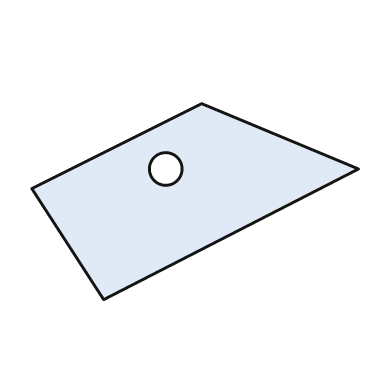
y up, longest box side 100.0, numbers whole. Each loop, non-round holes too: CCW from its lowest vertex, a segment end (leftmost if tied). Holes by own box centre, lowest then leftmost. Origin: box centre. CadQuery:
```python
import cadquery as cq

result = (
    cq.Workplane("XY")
    .moveTo(-28.0, -30.0)
    .lineTo(50.0, 10.0)
    .lineTo(2.0, 30.0)
    .lineTo(-50.0, 4.0)
    .close()
    .moveTo(-9.0, 10.0)
    .circle(5.0)
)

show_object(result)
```